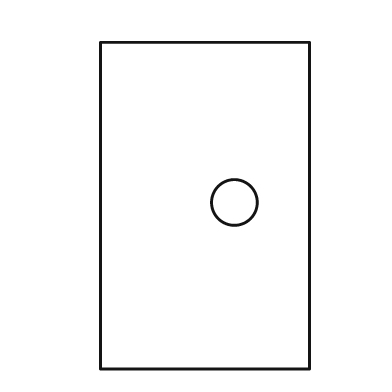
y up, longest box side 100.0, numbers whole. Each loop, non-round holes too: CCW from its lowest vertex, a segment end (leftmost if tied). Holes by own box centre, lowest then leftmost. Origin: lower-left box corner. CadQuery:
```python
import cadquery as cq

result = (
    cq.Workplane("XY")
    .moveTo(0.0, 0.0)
    .lineTo(64.0, 0.0)
    .lineTo(64.0, 100.0)
    .lineTo(0.0, 100.0)
    .close()
    .moveTo(41.0, 51.0)
    .circle(7.0)
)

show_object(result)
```